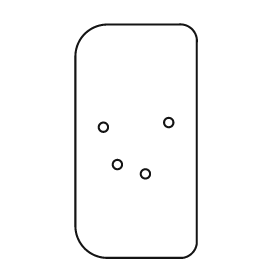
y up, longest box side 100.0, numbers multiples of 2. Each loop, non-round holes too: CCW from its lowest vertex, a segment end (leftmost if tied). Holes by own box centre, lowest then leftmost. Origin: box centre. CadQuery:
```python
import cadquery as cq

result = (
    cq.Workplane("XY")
    .moveTo(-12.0, -50.0)
    .lineTo(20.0, -50.0)
    .threePointArc((24.0, -48.0), (26.0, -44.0))
    .lineTo(26.0, 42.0)
    .threePointArc((24.0, 48.0), (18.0, 50.0))
    .lineTo(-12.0, 50.0)
    .threePointArc((-22.0, 46.0), (-26.0, 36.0))
    .lineTo(-26.0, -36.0)
    .threePointArc((-22.0, -46.0), (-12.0, -50.0))
    .close()
    .moveTo(4.0, -14.0)
    .circle(2.0)
    .moveTo(-8.0, -10.0)
    .circle(2.0)
    .moveTo(-14.0, 6.0)
    .circle(2.0)
    .moveTo(14.0, 8.0)
    .circle(2.0)
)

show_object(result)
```